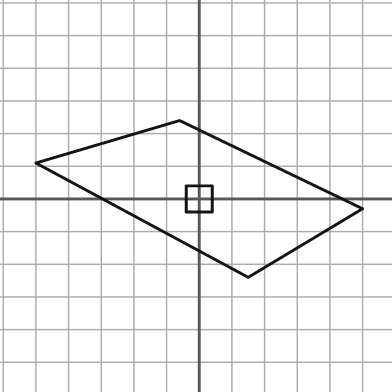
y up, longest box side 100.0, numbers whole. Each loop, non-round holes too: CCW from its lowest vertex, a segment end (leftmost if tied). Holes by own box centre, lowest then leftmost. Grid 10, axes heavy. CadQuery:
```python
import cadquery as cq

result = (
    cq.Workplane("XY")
    .moveTo(15.0, -24.0)
    .lineTo(50.0, -3.0)
    .lineTo(-6.0, 24.0)
    .lineTo(-50.0, 11.0)
    .close()
    .moveTo(-4.0, -4.0)
    .lineTo(4.0, -4.0)
    .lineTo(4.0, 4.0)
    .lineTo(-4.0, 4.0)
    .close()
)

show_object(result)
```